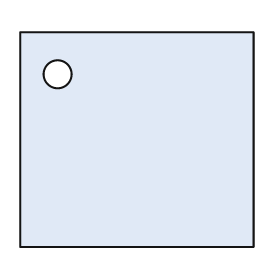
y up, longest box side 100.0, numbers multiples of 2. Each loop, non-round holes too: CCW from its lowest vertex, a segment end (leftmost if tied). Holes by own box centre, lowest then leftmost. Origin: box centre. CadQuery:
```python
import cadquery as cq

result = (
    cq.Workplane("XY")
    .moveTo(-50.0, -46.0)
    .lineTo(50.0, -46.0)
    .lineTo(50.0, 46.0)
    .lineTo(-50.0, 46.0)
    .close()
    .moveTo(-34.0, 28.0)
    .circle(6.0)
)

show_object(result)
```